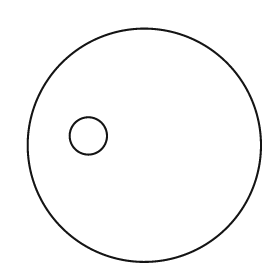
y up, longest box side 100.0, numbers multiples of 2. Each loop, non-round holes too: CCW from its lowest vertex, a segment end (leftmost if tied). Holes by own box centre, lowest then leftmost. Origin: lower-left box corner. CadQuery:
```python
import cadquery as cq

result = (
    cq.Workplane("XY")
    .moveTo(50.0, 50.0)
    .circle(50.0)
    .moveTo(26.0, 54.0)
    .circle(8.0)
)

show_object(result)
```